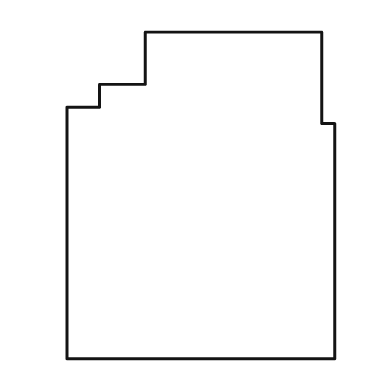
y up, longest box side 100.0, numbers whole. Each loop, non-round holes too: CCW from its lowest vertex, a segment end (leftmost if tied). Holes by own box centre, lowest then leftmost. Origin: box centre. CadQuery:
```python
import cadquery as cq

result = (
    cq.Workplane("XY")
    .moveTo(-41.0, -50.0)
    .lineTo(41.0, -50.0)
    .lineTo(41.0, 22.0)
    .lineTo(37.0, 22.0)
    .lineTo(37.0, 50.0)
    .lineTo(-17.0, 50.0)
    .lineTo(-17.0, 34.0)
    .lineTo(-31.0, 34.0)
    .lineTo(-31.0, 27.0)
    .lineTo(-41.0, 27.0)
    .close()
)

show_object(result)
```